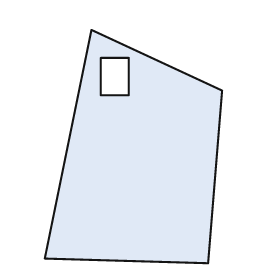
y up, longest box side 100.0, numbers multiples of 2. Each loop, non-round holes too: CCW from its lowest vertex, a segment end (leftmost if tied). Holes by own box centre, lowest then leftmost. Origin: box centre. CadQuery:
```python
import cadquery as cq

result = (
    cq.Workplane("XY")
    .moveTo(32.0, -50.0)
    .lineTo(38.0, 24.0)
    .lineTo(-18.0, 50.0)
    .lineTo(-38.0, -48.0)
    .close()
    .moveTo(-14.0, 22.0)
    .lineTo(-2.0, 22.0)
    .lineTo(-2.0, 38.0)
    .lineTo(-14.0, 38.0)
    .close()
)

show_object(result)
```